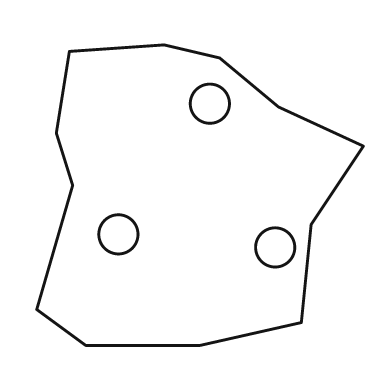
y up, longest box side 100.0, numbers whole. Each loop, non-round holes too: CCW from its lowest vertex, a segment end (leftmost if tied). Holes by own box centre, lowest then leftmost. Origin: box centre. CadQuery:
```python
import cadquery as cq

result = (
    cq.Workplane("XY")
    .moveTo(-35.0, -46.0)
    .lineTo(0.0, -46.0)
    .lineTo(31.0, -39.0)
    .lineTo(34.0, -9.0)
    .lineTo(50.0, 15.0)
    .lineTo(24.0, 27.0)
    .lineTo(6.0, 42.0)
    .lineTo(-11.0, 46.0)
    .lineTo(-40.0, 44.0)
    .lineTo(-44.0, 19.0)
    .lineTo(-39.0, 3.0)
    .lineTo(-50.0, -35.0)
    .close()
    .moveTo(23.0, -16.0)
    .circle(6.0)
    .moveTo(-25.0, -12.0)
    .circle(6.0)
    .moveTo(3.0, 28.0)
    .circle(6.0)
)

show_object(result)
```